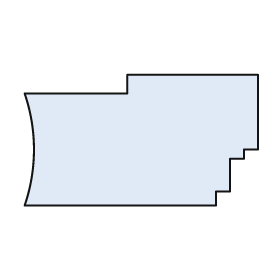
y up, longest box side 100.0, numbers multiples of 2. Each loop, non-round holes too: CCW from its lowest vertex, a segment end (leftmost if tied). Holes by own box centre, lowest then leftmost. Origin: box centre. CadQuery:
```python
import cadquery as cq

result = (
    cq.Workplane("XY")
    .moveTo(-50.0, -28.0)
    .lineTo(32.0, -28.0)
    .lineTo(32.0, -22.0)
    .lineTo(38.0, -22.0)
    .lineTo(38.0, -8.0)
    .lineTo(44.0, -8.0)
    .lineTo(44.0, -4.0)
    .lineTo(50.0, -4.0)
    .lineTo(50.0, 28.0)
    .lineTo(-6.0, 28.0)
    .lineTo(-6.0, 20.0)
    .lineTo(-50.0, 20.0)
    .threePointArc((-46.0, -4.0), (-50.0, -28.0))
    .close()
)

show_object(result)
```